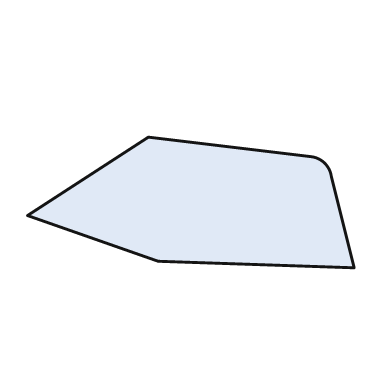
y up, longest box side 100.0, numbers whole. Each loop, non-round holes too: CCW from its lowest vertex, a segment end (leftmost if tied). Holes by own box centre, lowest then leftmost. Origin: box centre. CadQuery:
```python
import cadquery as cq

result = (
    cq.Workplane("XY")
    .moveTo(50.0, -20.0)
    .lineTo(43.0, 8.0)
    .threePointArc((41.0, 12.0), (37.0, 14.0))
    .lineTo(-13.0, 20.0)
    .lineTo(-50.0, -4.0)
    .lineTo(-10.0, -18.0)
    .close()
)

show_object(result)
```